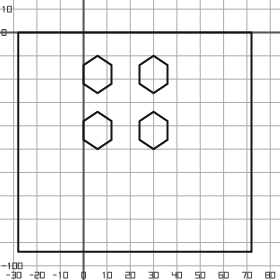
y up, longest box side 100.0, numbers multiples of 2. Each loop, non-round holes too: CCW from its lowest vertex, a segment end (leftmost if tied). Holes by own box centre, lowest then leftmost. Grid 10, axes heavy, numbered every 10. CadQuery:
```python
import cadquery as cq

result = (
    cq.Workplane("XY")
    .moveTo(-28.0, -94.0)
    .lineTo(72.0, -94.0)
    .lineTo(72.0, 0.0)
    .lineTo(-28.0, 0.0)
    .close()
    .moveTo(6.0, -50.0)
    .lineTo(12.0, -46.0)
    .lineTo(12.0, -38.0)
    .lineTo(6.0, -34.0)
    .lineTo(0.0, -38.0)
    .lineTo(0.0, -46.0)
    .close()
    .moveTo(30.0, -50.0)
    .lineTo(36.0, -46.0)
    .lineTo(36.0, -38.0)
    .lineTo(30.0, -34.0)
    .lineTo(24.0, -38.0)
    .lineTo(24.0, -46.0)
    .close()
    .moveTo(6.0, -26.0)
    .lineTo(12.0, -22.0)
    .lineTo(12.0, -14.0)
    .lineTo(6.0, -10.0)
    .lineTo(0.0, -14.0)
    .lineTo(0.0, -22.0)
    .close()
    .moveTo(30.0, -26.0)
    .lineTo(36.0, -22.0)
    .lineTo(36.0, -14.0)
    .lineTo(30.0, -10.0)
    .lineTo(24.0, -14.0)
    .lineTo(24.0, -22.0)
    .close()
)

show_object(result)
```